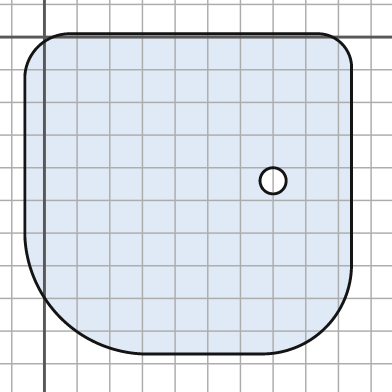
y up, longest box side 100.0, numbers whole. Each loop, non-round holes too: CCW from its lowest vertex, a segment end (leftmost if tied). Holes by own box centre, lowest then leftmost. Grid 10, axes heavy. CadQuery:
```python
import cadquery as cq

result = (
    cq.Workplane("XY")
    .moveTo(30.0, -97.0)
    .lineTo(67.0, -97.0)
    .threePointArc((86.0, -89.0), (94.0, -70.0))
    .lineTo(94.0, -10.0)
    .threePointArc((91.0, -2.0), (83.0, 1.0))
    .lineTo(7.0, 1.0)
    .threePointArc((-2.0, -3.0), (-6.0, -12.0))
    .lineTo(-6.0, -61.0)
    .threePointArc((5.0, -86.0), (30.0, -97.0))
    .close()
    .moveTo(70.0, -44.0)
    .circle(4.0)
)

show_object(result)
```